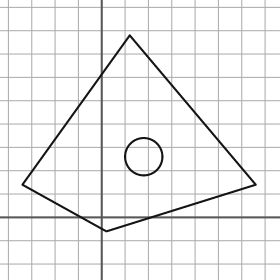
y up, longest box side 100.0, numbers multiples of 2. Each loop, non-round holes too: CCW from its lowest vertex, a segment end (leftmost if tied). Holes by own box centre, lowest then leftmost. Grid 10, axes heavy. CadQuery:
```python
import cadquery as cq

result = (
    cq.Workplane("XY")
    .moveTo(2.0, -6.0)
    .lineTo(66.0, 14.0)
    .lineTo(12.0, 78.0)
    .lineTo(-34.0, 14.0)
    .close()
    .moveTo(18.0, 26.0)
    .circle(8.0)
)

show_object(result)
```